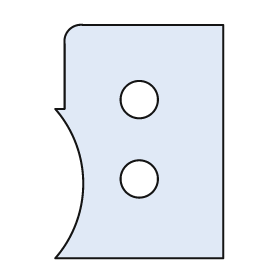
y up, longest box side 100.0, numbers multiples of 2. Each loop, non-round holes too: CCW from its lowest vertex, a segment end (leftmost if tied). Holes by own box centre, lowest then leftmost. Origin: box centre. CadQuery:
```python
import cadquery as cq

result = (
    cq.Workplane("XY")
    .moveTo(-36.0, -50.0)
    .lineTo(36.0, -50.0)
    .lineTo(36.0, 50.0)
    .lineTo(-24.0, 50.0)
    .threePointArc((-30.0, 48.0), (-32.0, 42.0))
    .lineTo(-32.0, 14.0)
    .lineTo(-36.0, 14.0)
    .threePointArc((-24.0, -18.0), (-36.0, -50.0))
    .close()
    .moveTo(0.0, -16.0)
    .circle(8.0)
    .moveTo(0.0, 18.0)
    .circle(8.0)
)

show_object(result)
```